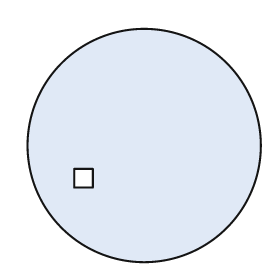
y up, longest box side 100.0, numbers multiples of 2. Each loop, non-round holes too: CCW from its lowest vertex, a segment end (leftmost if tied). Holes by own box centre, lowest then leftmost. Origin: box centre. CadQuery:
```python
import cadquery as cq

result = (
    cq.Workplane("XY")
    .moveTo(0.0, 0.0)
    .circle(50.0)
    .moveTo(-30.0, -18.0)
    .lineTo(-22.0, -18.0)
    .lineTo(-22.0, -10.0)
    .lineTo(-30.0, -10.0)
    .close()
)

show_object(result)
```